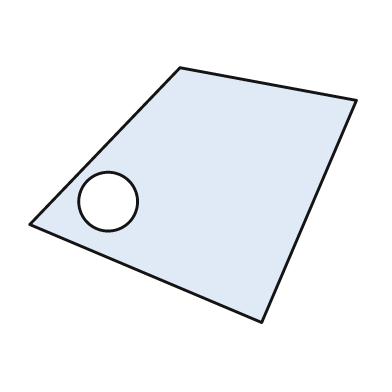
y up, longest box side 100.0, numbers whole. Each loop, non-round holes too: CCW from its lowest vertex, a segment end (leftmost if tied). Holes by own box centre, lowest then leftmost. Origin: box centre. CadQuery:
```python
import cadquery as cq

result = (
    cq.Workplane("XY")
    .moveTo(21.0, -39.0)
    .lineTo(50.0, 29.0)
    .lineTo(-4.0, 39.0)
    .lineTo(-50.0, -9.0)
    .close()
    .moveTo(-26.0, -2.0)
    .circle(9.0)
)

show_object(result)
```